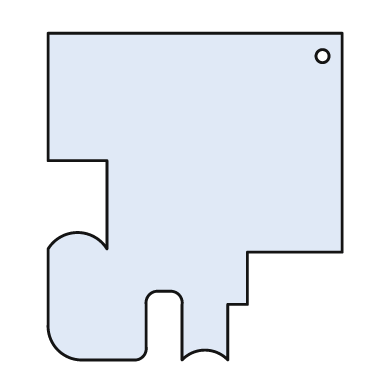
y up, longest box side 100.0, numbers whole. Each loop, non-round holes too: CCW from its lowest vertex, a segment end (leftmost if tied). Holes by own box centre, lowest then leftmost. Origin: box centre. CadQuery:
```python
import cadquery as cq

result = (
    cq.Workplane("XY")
    .moveTo(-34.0, -50.0)
    .lineTo(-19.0, -50.0)
    .threePointArc((-16.0, -49.0), (-15.0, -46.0))
    .lineTo(-15.0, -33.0)
    .threePointArc((-14.0, -30.0), (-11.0, -29.0))
    .lineTo(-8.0, -29.0)
    .threePointArc((-5.0, -30.0), (-4.0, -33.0))
    .lineTo(-4.0, -50.0)
    .threePointArc((3.0, -47.0), (10.0, -50.0))
    .lineTo(10.0, -33.0)
    .lineTo(16.0, -33.0)
    .lineTo(16.0, -17.0)
    .lineTo(45.0, -17.0)
    .lineTo(45.0, 50.0)
    .lineTo(-45.0, 50.0)
    .lineTo(-45.0, 11.0)
    .lineTo(-27.0, 11.0)
    .lineTo(-27.0, -16.0)
    .threePointArc((-36.0, -11.0), (-45.0, -16.0))
    .lineTo(-45.0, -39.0)
    .threePointArc((-42.0, -47.0), (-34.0, -50.0))
    .close()
    .moveTo(39.0, 43.0)
    .circle(2.0)
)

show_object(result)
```